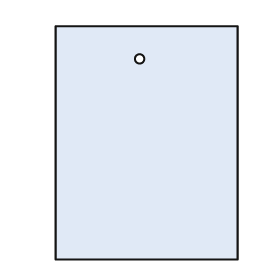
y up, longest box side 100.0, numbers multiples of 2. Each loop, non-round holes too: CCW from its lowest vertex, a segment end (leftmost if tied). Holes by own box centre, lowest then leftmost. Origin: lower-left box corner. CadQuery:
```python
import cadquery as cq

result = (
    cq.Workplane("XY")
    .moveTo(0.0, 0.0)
    .lineTo(78.0, 0.0)
    .lineTo(78.0, 100.0)
    .lineTo(0.0, 100.0)
    .close()
    .moveTo(36.0, 86.0)
    .circle(2.0)
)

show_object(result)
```